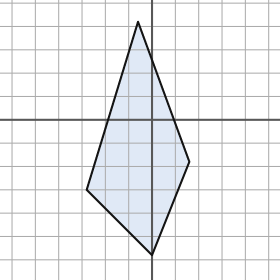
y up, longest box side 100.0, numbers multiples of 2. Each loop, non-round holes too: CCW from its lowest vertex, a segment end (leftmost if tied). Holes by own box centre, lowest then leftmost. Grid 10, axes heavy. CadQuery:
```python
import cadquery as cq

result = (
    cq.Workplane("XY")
    .moveTo(0.0, -58.0)
    .lineTo(16.0, -18.0)
    .lineTo(-6.0, 42.0)
    .lineTo(-28.0, -30.0)
    .close()
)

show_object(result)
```